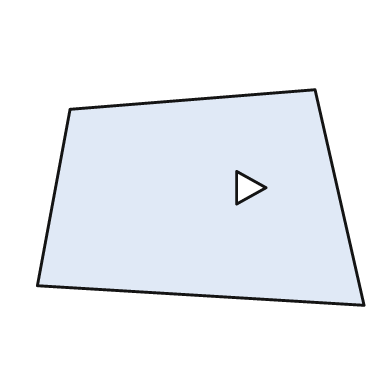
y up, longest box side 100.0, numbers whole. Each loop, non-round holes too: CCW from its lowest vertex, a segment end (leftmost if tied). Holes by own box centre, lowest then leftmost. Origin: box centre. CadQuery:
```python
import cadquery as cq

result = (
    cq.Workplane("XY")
    .moveTo(50.0, -33.0)
    .lineTo(35.0, 33.0)
    .lineTo(-40.0, 27.0)
    .lineTo(-50.0, -27.0)
    .close()
    .moveTo(11.0, -2.0)
    .lineTo(20.0, 3.0)
    .lineTo(11.0, 8.0)
    .close()
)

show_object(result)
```